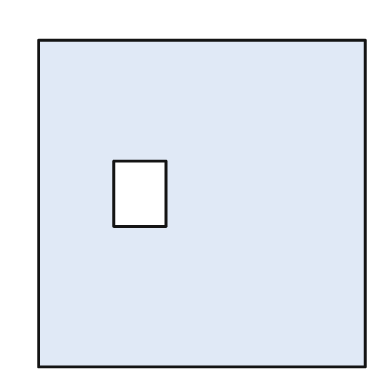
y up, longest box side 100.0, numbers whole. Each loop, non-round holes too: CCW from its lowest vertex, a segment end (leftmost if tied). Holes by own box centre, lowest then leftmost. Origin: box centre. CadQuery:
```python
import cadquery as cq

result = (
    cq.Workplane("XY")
    .moveTo(-50.0, -50.0)
    .lineTo(50.0, -50.0)
    .lineTo(50.0, 50.0)
    .lineTo(-50.0, 50.0)
    .close()
    .moveTo(-27.0, -7.0)
    .lineTo(-11.0, -7.0)
    .lineTo(-11.0, 13.0)
    .lineTo(-27.0, 13.0)
    .close()
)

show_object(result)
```